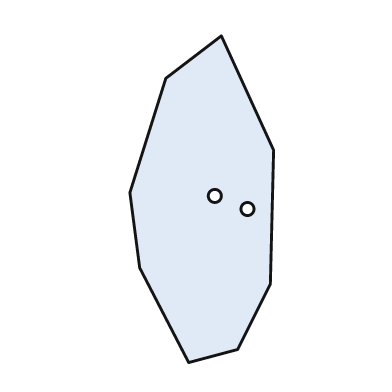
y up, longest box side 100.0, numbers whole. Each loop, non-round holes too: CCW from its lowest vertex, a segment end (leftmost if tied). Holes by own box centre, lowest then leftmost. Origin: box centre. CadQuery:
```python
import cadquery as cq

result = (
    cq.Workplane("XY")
    .moveTo(-4.0, -50.0)
    .lineTo(11.0, -46.0)
    .lineTo(21.0, -26.0)
    .lineTo(22.0, 15.0)
    .lineTo(6.0, 50.0)
    .lineTo(-11.0, 37.0)
    .lineTo(-22.0, 2.0)
    .lineTo(-19.0, -21.0)
    .close()
    .moveTo(14.0, -3.0)
    .circle(2.0)
    .moveTo(4.0, 1.0)
    .circle(2.0)
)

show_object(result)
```